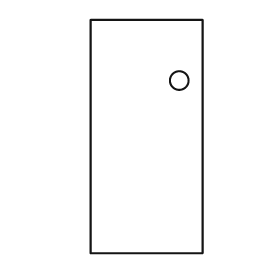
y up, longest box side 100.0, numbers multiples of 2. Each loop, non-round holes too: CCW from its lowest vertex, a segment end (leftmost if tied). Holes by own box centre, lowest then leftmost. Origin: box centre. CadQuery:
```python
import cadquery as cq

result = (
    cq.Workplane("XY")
    .moveTo(-24.0, -50.0)
    .lineTo(24.0, -50.0)
    .lineTo(24.0, 50.0)
    .lineTo(-24.0, 50.0)
    .close()
    .moveTo(14.0, 24.0)
    .circle(4.0)
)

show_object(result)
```